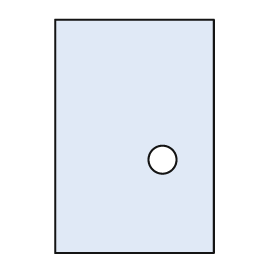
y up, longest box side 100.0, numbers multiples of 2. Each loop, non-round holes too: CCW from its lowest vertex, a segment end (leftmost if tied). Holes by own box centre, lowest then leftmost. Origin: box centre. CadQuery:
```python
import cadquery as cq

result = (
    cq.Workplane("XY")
    .moveTo(-34.0, -50.0)
    .lineTo(34.0, -50.0)
    .lineTo(34.0, 50.0)
    .lineTo(-34.0, 50.0)
    .close()
    .moveTo(12.0, -10.0)
    .circle(6.0)
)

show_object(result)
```